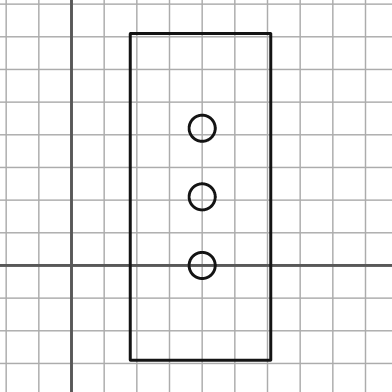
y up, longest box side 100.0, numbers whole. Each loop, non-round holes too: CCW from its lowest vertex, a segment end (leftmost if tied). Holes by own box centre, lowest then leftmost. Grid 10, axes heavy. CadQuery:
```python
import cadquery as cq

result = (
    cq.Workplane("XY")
    .moveTo(18.0, -29.0)
    .lineTo(61.0, -29.0)
    .lineTo(61.0, 71.0)
    .lineTo(18.0, 71.0)
    .close()
    .moveTo(40.0, 0.0)
    .circle(4.0)
    .moveTo(40.0, 21.0)
    .circle(4.0)
    .moveTo(40.0, 42.0)
    .circle(4.0)
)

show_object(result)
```